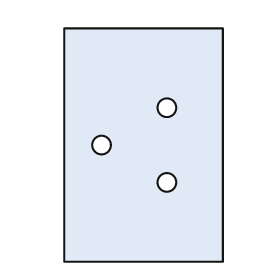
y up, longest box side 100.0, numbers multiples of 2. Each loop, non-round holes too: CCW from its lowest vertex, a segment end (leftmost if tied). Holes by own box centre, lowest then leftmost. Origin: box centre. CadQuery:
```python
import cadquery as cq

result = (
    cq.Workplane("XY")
    .moveTo(-34.0, -50.0)
    .lineTo(34.0, -50.0)
    .lineTo(34.0, 50.0)
    .lineTo(-34.0, 50.0)
    .close()
    .moveTo(10.0, -16.0)
    .circle(4.0)
    .moveTo(-18.0, 0.0)
    .circle(4.0)
    .moveTo(10.0, 16.0)
    .circle(4.0)
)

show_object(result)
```